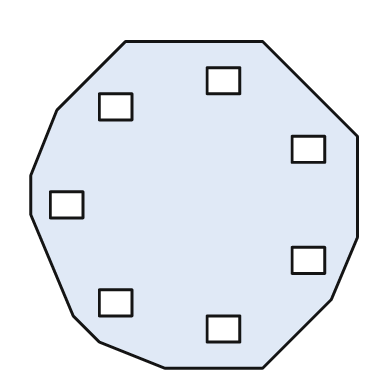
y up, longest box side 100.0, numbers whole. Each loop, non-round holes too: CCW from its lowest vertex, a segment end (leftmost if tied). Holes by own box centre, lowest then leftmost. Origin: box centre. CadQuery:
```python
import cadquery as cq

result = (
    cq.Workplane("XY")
    .moveTo(-9.0, -50.0)
    .lineTo(21.0, -50.0)
    .lineTo(42.0, -29.0)
    .lineTo(50.0, -10.0)
    .lineTo(50.0, 21.0)
    .lineTo(21.0, 50.0)
    .lineTo(-21.0, 50.0)
    .lineTo(-42.0, 29.0)
    .lineTo(-50.0, 9.0)
    .lineTo(-50.0, -3.0)
    .lineTo(-37.0, -34.0)
    .lineTo(-29.0, -42.0)
    .close()
    .moveTo(4.0, -42.0)
    .lineTo(14.0, -42.0)
    .lineTo(14.0, -34.0)
    .lineTo(4.0, -34.0)
    .close()
    .moveTo(-29.0, -34.0)
    .lineTo(-19.0, -34.0)
    .lineTo(-19.0, -26.0)
    .lineTo(-29.0, -26.0)
    .close()
    .moveTo(30.0, -21.0)
    .lineTo(40.0, -21.0)
    .lineTo(40.0, -13.0)
    .lineTo(30.0, -13.0)
    .close()
    .moveTo(-44.0, -4.0)
    .lineTo(-34.0, -4.0)
    .lineTo(-34.0, 4.0)
    .lineTo(-44.0, 4.0)
    .close()
    .moveTo(30.0, 13.0)
    .lineTo(40.0, 13.0)
    .lineTo(40.0, 21.0)
    .lineTo(30.0, 21.0)
    .close()
    .moveTo(-29.0, 26.0)
    .lineTo(-19.0, 26.0)
    .lineTo(-19.0, 34.0)
    .lineTo(-29.0, 34.0)
    .close()
    .moveTo(4.0, 34.0)
    .lineTo(14.0, 34.0)
    .lineTo(14.0, 42.0)
    .lineTo(4.0, 42.0)
    .close()
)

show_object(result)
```